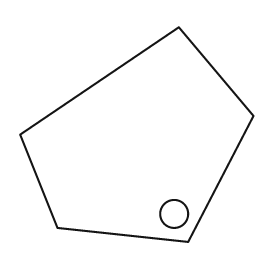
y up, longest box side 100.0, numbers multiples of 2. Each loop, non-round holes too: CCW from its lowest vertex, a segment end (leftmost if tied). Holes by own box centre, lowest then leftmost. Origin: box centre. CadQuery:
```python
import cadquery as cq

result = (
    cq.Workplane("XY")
    .moveTo(22.0, -46.0)
    .lineTo(50.0, 8.0)
    .lineTo(18.0, 46.0)
    .lineTo(-50.0, 0.0)
    .lineTo(-34.0, -40.0)
    .close()
    .moveTo(16.0, -34.0)
    .circle(6.0)
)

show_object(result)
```